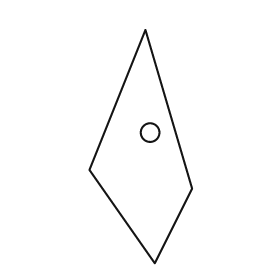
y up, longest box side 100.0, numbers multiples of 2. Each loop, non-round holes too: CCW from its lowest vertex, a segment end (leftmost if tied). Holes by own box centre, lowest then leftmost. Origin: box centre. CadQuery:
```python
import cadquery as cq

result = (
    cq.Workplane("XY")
    .moveTo(6.0, -50.0)
    .lineTo(22.0, -18.0)
    .lineTo(2.0, 50.0)
    .lineTo(-22.0, -10.0)
    .close()
    .moveTo(4.0, 6.0)
    .circle(4.0)
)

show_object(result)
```